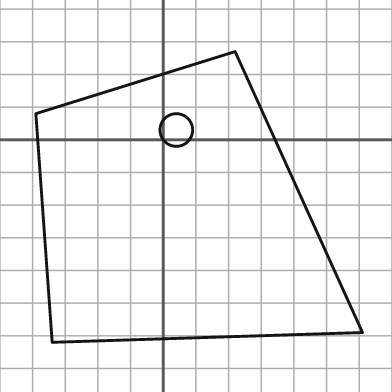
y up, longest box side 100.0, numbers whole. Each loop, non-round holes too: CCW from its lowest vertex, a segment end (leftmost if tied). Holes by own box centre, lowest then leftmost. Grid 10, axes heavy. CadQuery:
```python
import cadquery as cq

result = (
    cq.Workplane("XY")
    .moveTo(-34.0, -62.0)
    .lineTo(61.0, -59.0)
    .lineTo(22.0, 27.0)
    .lineTo(-39.0, 8.0)
    .close()
    .moveTo(4.0, 3.0)
    .circle(5.0)
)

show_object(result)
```